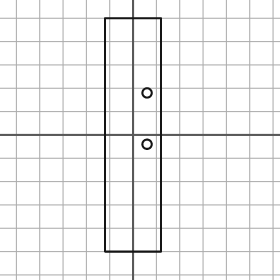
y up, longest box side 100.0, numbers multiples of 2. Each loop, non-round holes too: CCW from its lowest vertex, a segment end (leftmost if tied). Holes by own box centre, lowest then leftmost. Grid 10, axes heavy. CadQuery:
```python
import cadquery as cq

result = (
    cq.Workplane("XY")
    .moveTo(-12.0, -50.0)
    .lineTo(12.0, -50.0)
    .lineTo(12.0, 50.0)
    .lineTo(-12.0, 50.0)
    .close()
    .moveTo(6.0, -4.0)
    .circle(2.0)
    .moveTo(6.0, 18.0)
    .circle(2.0)
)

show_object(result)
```